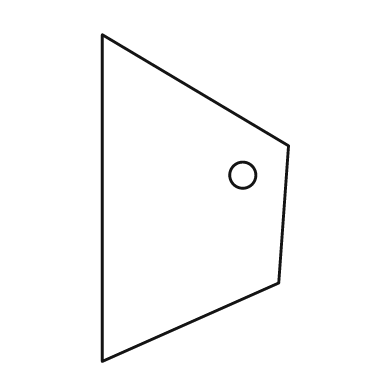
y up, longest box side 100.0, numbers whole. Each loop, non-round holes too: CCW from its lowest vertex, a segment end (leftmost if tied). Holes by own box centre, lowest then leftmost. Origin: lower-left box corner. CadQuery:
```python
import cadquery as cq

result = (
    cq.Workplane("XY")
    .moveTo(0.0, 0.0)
    .lineTo(54.0, 24.0)
    .lineTo(57.0, 66.0)
    .lineTo(0.0, 100.0)
    .close()
    .moveTo(43.0, 57.0)
    .circle(4.0)
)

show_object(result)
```